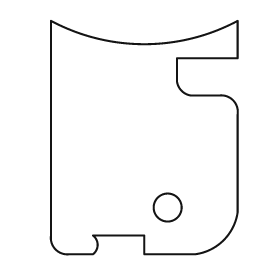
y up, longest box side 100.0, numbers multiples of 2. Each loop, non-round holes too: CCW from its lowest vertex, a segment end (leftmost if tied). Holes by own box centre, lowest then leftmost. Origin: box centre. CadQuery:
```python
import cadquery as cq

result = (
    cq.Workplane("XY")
    .moveTo(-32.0, -50.0)
    .lineTo(-22.0, -50.0)
    .threePointArc((-20.0, -46.0), (-22.0, -42.0))
    .lineTo(0.0, -42.0)
    .lineTo(0.0, -50.0)
    .lineTo(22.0, -50.0)
    .threePointArc((34.0, -44.0), (40.0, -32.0))
    .lineTo(40.0, 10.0)
    .threePointArc((38.0, 16.0), (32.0, 18.0))
    .lineTo(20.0, 18.0)
    .threePointArc((16.0, 20.0), (14.0, 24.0))
    .lineTo(14.0, 34.0)
    .lineTo(40.0, 34.0)
    .lineTo(40.0, 50.0)
    .threePointArc((0.0, 40.0), (-40.0, 50.0))
    .lineTo(-40.0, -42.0)
    .threePointArc((-38.0, -48.0), (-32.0, -50.0))
    .close()
    .moveTo(10.0, -30.0)
    .circle(6.0)
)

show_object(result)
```